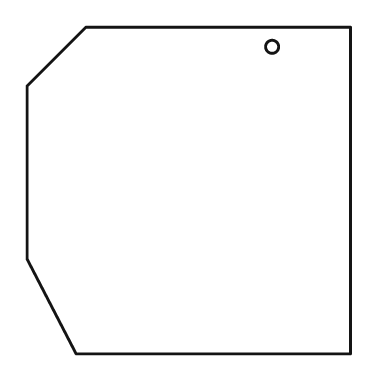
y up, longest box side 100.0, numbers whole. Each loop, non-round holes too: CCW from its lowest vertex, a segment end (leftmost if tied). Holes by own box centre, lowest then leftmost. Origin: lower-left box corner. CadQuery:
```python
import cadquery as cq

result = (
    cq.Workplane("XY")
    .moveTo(15.0, 0.0)
    .lineTo(99.0, 0.0)
    .lineTo(99.0, 100.0)
    .lineTo(18.0, 100.0)
    .lineTo(0.0, 82.0)
    .lineTo(0.0, 29.0)
    .close()
    .moveTo(75.0, 94.0)
    .circle(2.0)
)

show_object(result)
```